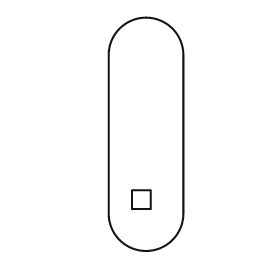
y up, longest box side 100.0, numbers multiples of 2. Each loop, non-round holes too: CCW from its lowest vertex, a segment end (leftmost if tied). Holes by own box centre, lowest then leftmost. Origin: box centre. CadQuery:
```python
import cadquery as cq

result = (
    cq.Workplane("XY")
    .moveTo(-16.0, -34.0)
    .threePointArc((0.0, -50.0), (16.0, -34.0))
    .lineTo(16.0, 34.0)
    .threePointArc((0.0, 50.0), (-16.0, 34.0))
    .close()
    .moveTo(-6.0, -32.0)
    .lineTo(2.0, -32.0)
    .lineTo(2.0, -24.0)
    .lineTo(-6.0, -24.0)
    .close()
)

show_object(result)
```